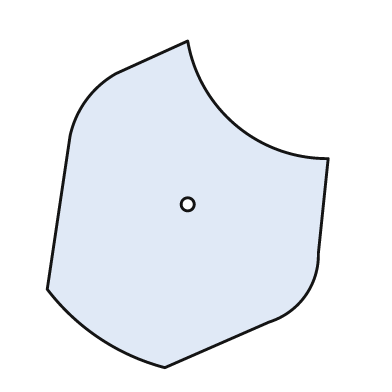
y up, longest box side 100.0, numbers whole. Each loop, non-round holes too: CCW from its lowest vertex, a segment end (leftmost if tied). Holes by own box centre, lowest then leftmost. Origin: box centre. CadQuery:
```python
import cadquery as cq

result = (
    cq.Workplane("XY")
    .moveTo(-7.0, -50.0)
    .lineTo(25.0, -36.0)
    .threePointArc((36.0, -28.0), (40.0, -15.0))
    .lineTo(43.0, 14.0)
    .threePointArc((15.0, 24.0), (0.0, 50.0))
    .lineTo(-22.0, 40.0)
    .threePointArc((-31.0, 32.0), (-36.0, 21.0))
    .lineTo(-43.0, -26.0)
    .threePointArc((-27.0, -41.0), (-7.0, -50.0))
    .close()
    .moveTo(0.0, 0.0)
    .circle(2.0)
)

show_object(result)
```